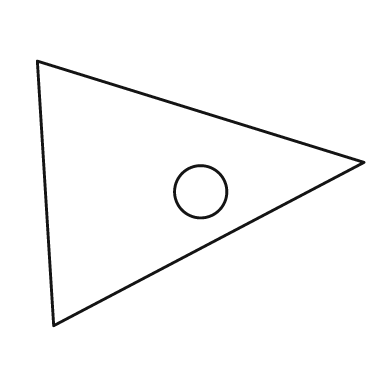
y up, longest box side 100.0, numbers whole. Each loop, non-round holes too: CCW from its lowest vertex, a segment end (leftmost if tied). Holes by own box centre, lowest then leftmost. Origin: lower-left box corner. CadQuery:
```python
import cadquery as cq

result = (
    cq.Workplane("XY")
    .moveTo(5.0, 0.0)
    .lineTo(100.0, 50.0)
    .lineTo(0.0, 81.0)
    .close()
    .moveTo(50.0, 41.0)
    .circle(8.0)
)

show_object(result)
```